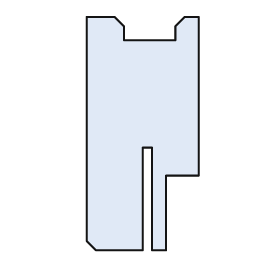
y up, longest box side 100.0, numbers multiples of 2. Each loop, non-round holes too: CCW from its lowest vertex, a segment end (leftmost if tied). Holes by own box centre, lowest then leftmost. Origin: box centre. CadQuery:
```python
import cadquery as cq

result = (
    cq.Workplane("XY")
    .moveTo(-20.0, -50.0)
    .lineTo(0.0, -50.0)
    .lineTo(0.0, -6.0)
    .lineTo(4.0, -6.0)
    .lineTo(4.0, -50.0)
    .lineTo(10.0, -50.0)
    .lineTo(10.0, -18.0)
    .lineTo(24.0, -18.0)
    .lineTo(24.0, 50.0)
    .lineTo(18.0, 50.0)
    .lineTo(14.0, 46.0)
    .lineTo(14.0, 40.0)
    .lineTo(-8.0, 40.0)
    .lineTo(-8.0, 46.0)
    .lineTo(-12.0, 50.0)
    .lineTo(-24.0, 50.0)
    .lineTo(-24.0, -46.0)
    .close()
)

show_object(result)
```